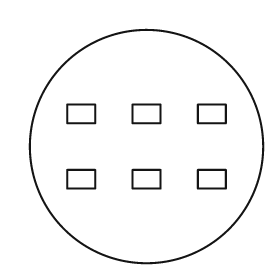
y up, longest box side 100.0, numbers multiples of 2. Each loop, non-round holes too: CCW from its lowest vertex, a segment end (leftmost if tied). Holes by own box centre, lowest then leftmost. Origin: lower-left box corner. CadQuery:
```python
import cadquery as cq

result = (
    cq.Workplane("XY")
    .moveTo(50.0, 50.0)
    .circle(50.0)
    .moveTo(16.0, 32.0)
    .lineTo(28.0, 32.0)
    .lineTo(28.0, 40.0)
    .lineTo(16.0, 40.0)
    .close()
    .moveTo(44.0, 32.0)
    .lineTo(56.0, 32.0)
    .lineTo(56.0, 40.0)
    .lineTo(44.0, 40.0)
    .close()
    .moveTo(72.0, 32.0)
    .lineTo(84.0, 32.0)
    .lineTo(84.0, 40.0)
    .lineTo(72.0, 40.0)
    .close()
    .moveTo(16.0, 60.0)
    .lineTo(28.0, 60.0)
    .lineTo(28.0, 68.0)
    .lineTo(16.0, 68.0)
    .close()
    .moveTo(44.0, 60.0)
    .lineTo(56.0, 60.0)
    .lineTo(56.0, 68.0)
    .lineTo(44.0, 68.0)
    .close()
    .moveTo(72.0, 60.0)
    .lineTo(84.0, 60.0)
    .lineTo(84.0, 68.0)
    .lineTo(72.0, 68.0)
    .close()
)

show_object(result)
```